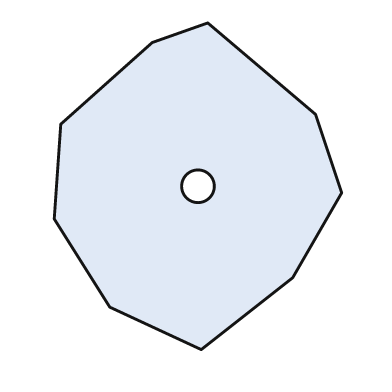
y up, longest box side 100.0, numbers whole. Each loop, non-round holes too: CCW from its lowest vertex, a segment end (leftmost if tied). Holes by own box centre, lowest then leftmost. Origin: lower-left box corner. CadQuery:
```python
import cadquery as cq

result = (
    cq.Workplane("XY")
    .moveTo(45.0, 0.0)
    .lineTo(73.0, 22.0)
    .lineTo(88.0, 48.0)
    .lineTo(80.0, 72.0)
    .lineTo(47.0, 100.0)
    .lineTo(30.0, 94.0)
    .lineTo(2.0, 69.0)
    .lineTo(0.0, 40.0)
    .lineTo(17.0, 13.0)
    .close()
    .moveTo(44.0, 50.0)
    .circle(5.0)
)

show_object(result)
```